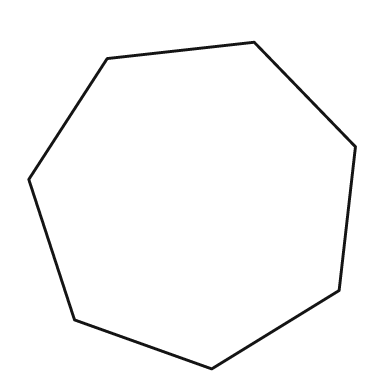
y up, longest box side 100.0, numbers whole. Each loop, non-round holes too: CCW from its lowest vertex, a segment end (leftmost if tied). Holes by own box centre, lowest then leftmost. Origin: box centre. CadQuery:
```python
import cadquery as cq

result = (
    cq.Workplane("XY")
    .moveTo(6.0, -50.0)
    .lineTo(45.0, -26.0)
    .lineTo(50.0, 18.0)
    .lineTo(19.0, 50.0)
    .lineTo(-26.0, 45.0)
    .lineTo(-50.0, 8.0)
    .lineTo(-36.0, -35.0)
    .close()
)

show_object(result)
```